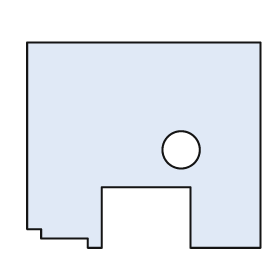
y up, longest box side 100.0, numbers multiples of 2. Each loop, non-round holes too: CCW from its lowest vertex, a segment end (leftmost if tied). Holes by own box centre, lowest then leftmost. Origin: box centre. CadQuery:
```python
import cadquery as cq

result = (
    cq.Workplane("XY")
    .moveTo(-24.0, -44.0)
    .lineTo(-18.0, -44.0)
    .lineTo(-18.0, -18.0)
    .lineTo(20.0, -18.0)
    .lineTo(20.0, -44.0)
    .lineTo(50.0, -44.0)
    .lineTo(50.0, 44.0)
    .lineTo(-50.0, 44.0)
    .lineTo(-50.0, -36.0)
    .lineTo(-44.0, -36.0)
    .lineTo(-44.0, -40.0)
    .lineTo(-24.0, -40.0)
    .close()
    .moveTo(16.0, -2.0)
    .circle(8.0)
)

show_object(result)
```